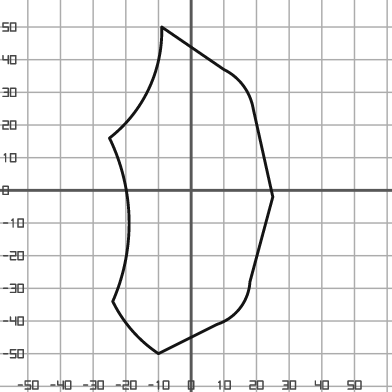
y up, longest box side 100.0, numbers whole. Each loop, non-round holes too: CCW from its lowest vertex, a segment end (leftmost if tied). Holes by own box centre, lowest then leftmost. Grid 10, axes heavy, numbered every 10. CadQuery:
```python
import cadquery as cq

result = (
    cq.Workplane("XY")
    .moveTo(-10.0, -50.0)
    .lineTo(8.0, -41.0)
    .threePointArc((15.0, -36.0), (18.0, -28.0))
    .lineTo(25.0, -2.0)
    .lineTo(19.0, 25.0)
    .threePointArc((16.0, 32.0), (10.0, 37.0))
    .lineTo(-9.0, 50.0)
    .threePointArc((-13.0, 31.0), (-25.0, 16.0))
    .threePointArc((-19.0, -9.0), (-24.0, -34.0))
    .threePointArc((-18.0, -43.0), (-10.0, -50.0))
    .close()
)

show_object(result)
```